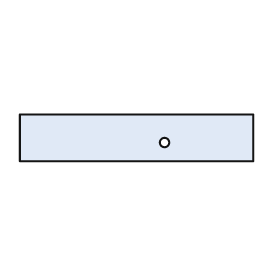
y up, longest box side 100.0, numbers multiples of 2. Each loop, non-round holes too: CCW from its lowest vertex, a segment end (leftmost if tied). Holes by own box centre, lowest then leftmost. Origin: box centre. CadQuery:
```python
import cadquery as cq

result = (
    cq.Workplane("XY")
    .moveTo(-50.0, -10.0)
    .lineTo(50.0, -10.0)
    .lineTo(50.0, 10.0)
    .lineTo(-50.0, 10.0)
    .close()
    .moveTo(12.0, -2.0)
    .circle(2.0)
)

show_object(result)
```